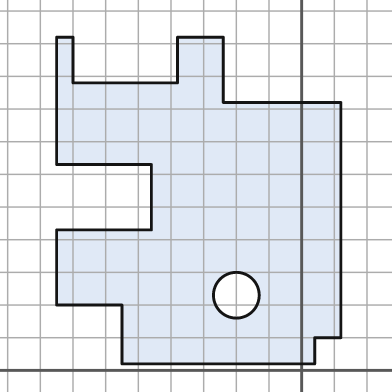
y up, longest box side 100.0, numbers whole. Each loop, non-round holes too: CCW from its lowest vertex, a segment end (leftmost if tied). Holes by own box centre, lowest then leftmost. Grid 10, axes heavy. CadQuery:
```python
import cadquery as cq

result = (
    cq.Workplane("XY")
    .moveTo(-55.0, 2.0)
    .lineTo(4.0, 2.0)
    .lineTo(4.0, 10.0)
    .lineTo(12.0, 10.0)
    .lineTo(12.0, 82.0)
    .lineTo(-24.0, 82.0)
    .lineTo(-24.0, 102.0)
    .lineTo(-38.0, 102.0)
    .lineTo(-38.0, 88.0)
    .lineTo(-70.0, 88.0)
    .lineTo(-70.0, 102.0)
    .lineTo(-75.0, 102.0)
    .lineTo(-75.0, 63.0)
    .lineTo(-46.0, 63.0)
    .lineTo(-46.0, 43.0)
    .lineTo(-75.0, 43.0)
    .lineTo(-75.0, 20.0)
    .lineTo(-55.0, 20.0)
    .close()
    .moveTo(-20.0, 23.0)
    .circle(7.0)
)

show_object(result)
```